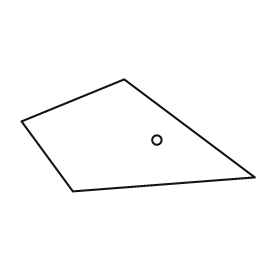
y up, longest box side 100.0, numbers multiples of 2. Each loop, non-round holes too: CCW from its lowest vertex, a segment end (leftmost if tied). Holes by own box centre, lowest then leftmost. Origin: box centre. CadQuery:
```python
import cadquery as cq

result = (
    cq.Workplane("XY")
    .moveTo(-28.0, -24.0)
    .lineTo(50.0, -18.0)
    .lineTo(-6.0, 24.0)
    .lineTo(-50.0, 6.0)
    .close()
    .moveTo(8.0, -2.0)
    .circle(2.0)
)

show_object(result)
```